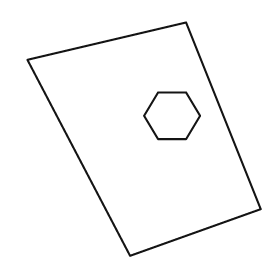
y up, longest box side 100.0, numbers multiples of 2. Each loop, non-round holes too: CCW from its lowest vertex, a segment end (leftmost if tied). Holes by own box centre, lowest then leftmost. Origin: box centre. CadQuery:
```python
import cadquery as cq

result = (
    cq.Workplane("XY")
    .moveTo(-6.0, -50.0)
    .lineTo(50.0, -30.0)
    .lineTo(18.0, 50.0)
    .lineTo(-50.0, 34.0)
    .close()
    .moveTo(6.0, 0.0)
    .lineTo(18.0, 0.0)
    .lineTo(24.0, 10.0)
    .lineTo(18.0, 20.0)
    .lineTo(6.0, 20.0)
    .lineTo(0.0, 10.0)
    .close()
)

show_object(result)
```